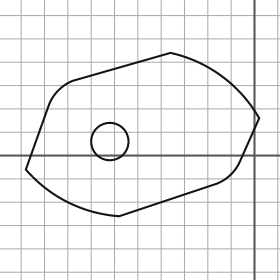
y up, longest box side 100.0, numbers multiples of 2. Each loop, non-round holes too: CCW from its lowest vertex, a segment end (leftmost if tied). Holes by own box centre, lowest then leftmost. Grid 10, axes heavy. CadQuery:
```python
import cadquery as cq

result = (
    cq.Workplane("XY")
    .moveTo(-58.0, -26.0)
    .lineTo(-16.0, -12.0)
    .threePointArc((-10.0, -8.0), (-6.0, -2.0))
    .lineTo(2.0, 16.0)
    .threePointArc((-14.0, 34.0), (-36.0, 44.0))
    .lineTo(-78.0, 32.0)
    .threePointArc((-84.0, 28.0), (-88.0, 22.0))
    .lineTo(-98.0, -6.0)
    .threePointArc((-80.0, -20.0), (-58.0, -26.0))
    .close()
    .moveTo(-62.0, 6.0)
    .circle(8.0)
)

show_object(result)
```